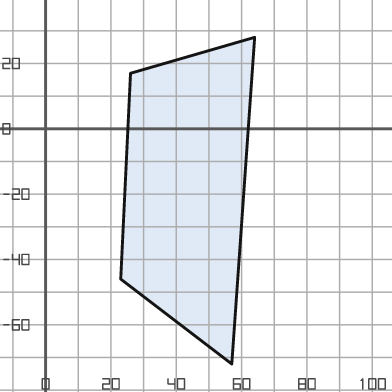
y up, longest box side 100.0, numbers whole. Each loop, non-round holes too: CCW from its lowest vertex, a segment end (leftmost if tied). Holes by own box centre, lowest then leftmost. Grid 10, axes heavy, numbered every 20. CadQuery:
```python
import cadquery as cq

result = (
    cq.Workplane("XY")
    .moveTo(57.0, -72.0)
    .lineTo(64.0, 28.0)
    .lineTo(26.0, 17.0)
    .lineTo(23.0, -46.0)
    .close()
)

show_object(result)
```